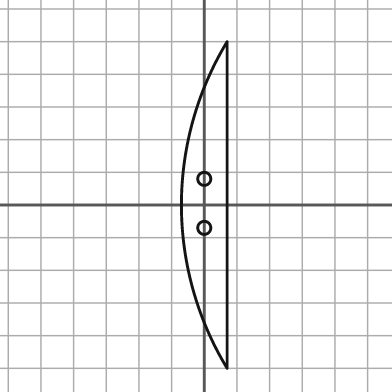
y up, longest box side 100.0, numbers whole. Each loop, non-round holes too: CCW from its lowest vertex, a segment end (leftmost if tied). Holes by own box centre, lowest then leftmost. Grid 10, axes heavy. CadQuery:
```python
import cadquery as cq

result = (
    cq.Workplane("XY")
    .moveTo(7.0, -50.0)
    .lineTo(7.0, 50.0)
    .threePointArc((-7.0, 0.0), (7.0, -50.0))
    .close()
    .moveTo(0.0, -7.0)
    .circle(2.0)
    .moveTo(0.0, 8.0)
    .circle(2.0)
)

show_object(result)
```